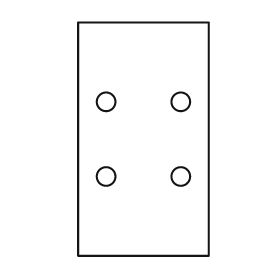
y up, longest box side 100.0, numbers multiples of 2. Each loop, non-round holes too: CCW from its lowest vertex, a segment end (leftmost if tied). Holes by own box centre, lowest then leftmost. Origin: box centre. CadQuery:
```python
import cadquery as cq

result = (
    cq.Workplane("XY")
    .moveTo(-28.0, -50.0)
    .lineTo(28.0, -50.0)
    .lineTo(28.0, 50.0)
    .lineTo(-28.0, 50.0)
    .close()
    .moveTo(-16.0, -16.0)
    .circle(4.0)
    .moveTo(16.0, -16.0)
    .circle(4.0)
    .moveTo(-16.0, 16.0)
    .circle(4.0)
    .moveTo(16.0, 16.0)
    .circle(4.0)
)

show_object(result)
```